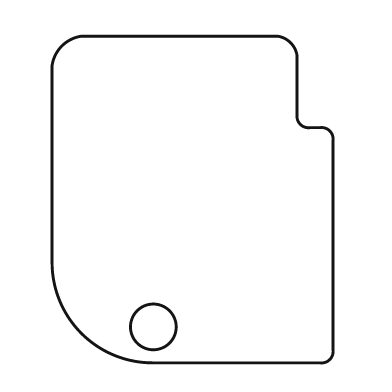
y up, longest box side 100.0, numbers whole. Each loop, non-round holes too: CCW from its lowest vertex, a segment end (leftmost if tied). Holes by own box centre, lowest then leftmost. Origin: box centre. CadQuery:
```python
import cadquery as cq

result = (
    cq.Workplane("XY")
    .moveTo(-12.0, -50.0)
    .lineTo(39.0, -50.0)
    .threePointArc((42.0, -49.0), (43.0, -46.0))
    .lineTo(43.0, 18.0)
    .threePointArc((42.0, 21.0), (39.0, 22.0))
    .lineTo(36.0, 22.0)
    .threePointArc((33.0, 23.0), (32.0, 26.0))
    .lineTo(32.0, 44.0)
    .threePointArc((30.0, 48.0), (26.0, 50.0))
    .lineTo(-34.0, 50.0)
    .threePointArc((-40.0, 47.0), (-43.0, 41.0))
    .lineTo(-43.0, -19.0)
    .threePointArc((-34.0, -41.0), (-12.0, -50.0))
    .close()
    .moveTo(-12.0, -39.0)
    .circle(7.0)
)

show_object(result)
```